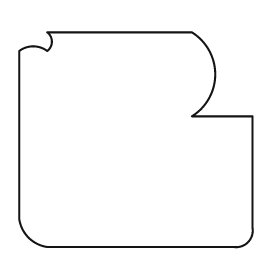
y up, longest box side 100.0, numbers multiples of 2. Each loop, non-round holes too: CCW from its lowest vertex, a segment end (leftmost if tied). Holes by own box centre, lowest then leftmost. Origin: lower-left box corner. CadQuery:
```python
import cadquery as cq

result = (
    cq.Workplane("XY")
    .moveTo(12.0, 0.0)
    .lineTo(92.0, 0.0)
    .threePointArc((98.0, 2.0), (100.0, 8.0))
    .lineTo(100.0, 56.0)
    .lineTo(74.0, 56.0)
    .threePointArc((84.0, 74.0), (74.0, 92.0))
    .lineTo(12.0, 92.0)
    .threePointArc((14.0, 88.0), (12.0, 84.0))
    .threePointArc((6.0, 86.0), (0.0, 84.0))
    .lineTo(0.0, 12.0)
    .threePointArc((4.0, 4.0), (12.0, 0.0))
    .close()
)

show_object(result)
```